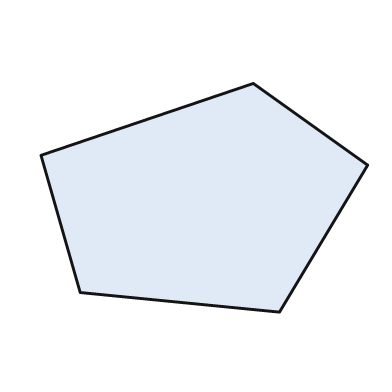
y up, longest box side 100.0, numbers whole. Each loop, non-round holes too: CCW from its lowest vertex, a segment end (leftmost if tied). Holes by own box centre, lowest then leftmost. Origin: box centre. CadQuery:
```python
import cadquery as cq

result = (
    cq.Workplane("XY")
    .moveTo(23.0, -35.0)
    .lineTo(50.0, 10.0)
    .lineTo(15.0, 35.0)
    .lineTo(-50.0, 13.0)
    .lineTo(-38.0, -29.0)
    .close()
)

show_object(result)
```